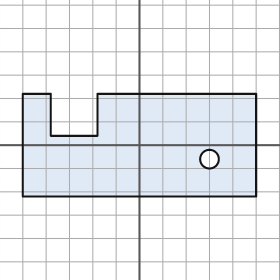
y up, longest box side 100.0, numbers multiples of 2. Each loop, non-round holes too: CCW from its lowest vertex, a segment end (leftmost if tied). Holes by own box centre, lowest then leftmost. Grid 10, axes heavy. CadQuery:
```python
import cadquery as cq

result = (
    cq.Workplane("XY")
    .moveTo(-50.0, -22.0)
    .lineTo(50.0, -22.0)
    .lineTo(50.0, 22.0)
    .lineTo(-18.0, 22.0)
    .lineTo(-18.0, 4.0)
    .lineTo(-38.0, 4.0)
    .lineTo(-38.0, 22.0)
    .lineTo(-50.0, 22.0)
    .close()
    .moveTo(30.0, -6.0)
    .circle(4.0)
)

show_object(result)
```